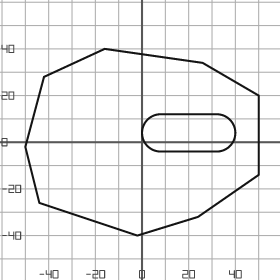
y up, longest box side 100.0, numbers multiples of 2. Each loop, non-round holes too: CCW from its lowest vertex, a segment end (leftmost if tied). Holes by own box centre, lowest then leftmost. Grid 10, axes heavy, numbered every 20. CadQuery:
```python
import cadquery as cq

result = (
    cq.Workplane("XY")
    .moveTo(-2.0, -40.0)
    .lineTo(24.0, -32.0)
    .lineTo(50.0, -14.0)
    .lineTo(50.0, 20.0)
    .lineTo(26.0, 34.0)
    .lineTo(-16.0, 40.0)
    .lineTo(-42.0, 28.0)
    .lineTo(-50.0, -2.0)
    .lineTo(-44.0, -26.0)
    .close()
    .moveTo(8.0, -4.0)
    .lineTo(32.0, -4.0)
    .threePointArc((40.0, 4.0), (32.0, 12.0))
    .lineTo(8.0, 12.0)
    .threePointArc((0.0, 4.0), (8.0, -4.0))
    .close()
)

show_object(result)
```